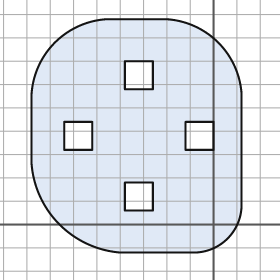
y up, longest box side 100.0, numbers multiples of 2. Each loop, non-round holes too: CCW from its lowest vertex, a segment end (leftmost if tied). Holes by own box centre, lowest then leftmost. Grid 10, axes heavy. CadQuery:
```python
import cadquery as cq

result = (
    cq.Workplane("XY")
    .moveTo(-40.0, -12.0)
    .lineTo(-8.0, -12.0)
    .threePointArc((6.0, -6.0), (12.0, 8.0))
    .lineTo(12.0, 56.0)
    .threePointArc((2.0, 78.0), (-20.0, 88.0))
    .lineTo(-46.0, 88.0)
    .threePointArc((-68.0, 78.0), (-78.0, 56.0))
    .lineTo(-78.0, 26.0)
    .threePointArc((-66.0, 0.0), (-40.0, -12.0))
    .close()
    .moveTo(-38.0, 6.0)
    .lineTo(-26.0, 6.0)
    .lineTo(-26.0, 18.0)
    .lineTo(-38.0, 18.0)
    .close()
    .moveTo(-64.0, 32.0)
    .lineTo(-52.0, 32.0)
    .lineTo(-52.0, 44.0)
    .lineTo(-64.0, 44.0)
    .close()
    .moveTo(-12.0, 32.0)
    .lineTo(0.0, 32.0)
    .lineTo(0.0, 44.0)
    .lineTo(-12.0, 44.0)
    .close()
    .moveTo(-38.0, 58.0)
    .lineTo(-26.0, 58.0)
    .lineTo(-26.0, 70.0)
    .lineTo(-38.0, 70.0)
    .close()
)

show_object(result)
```